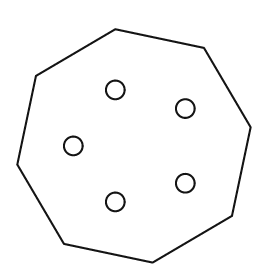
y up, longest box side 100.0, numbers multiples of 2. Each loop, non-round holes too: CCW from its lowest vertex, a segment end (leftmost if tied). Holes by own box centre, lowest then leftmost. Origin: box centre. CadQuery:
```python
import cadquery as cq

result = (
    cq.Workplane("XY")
    .moveTo(8.0, -50.0)
    .lineTo(42.0, -30.0)
    .lineTo(50.0, 8.0)
    .lineTo(30.0, 42.0)
    .lineTo(-8.0, 50.0)
    .lineTo(-42.0, 30.0)
    .lineTo(-50.0, -8.0)
    .lineTo(-30.0, -42.0)
    .close()
    .moveTo(-8.0, -24.0)
    .circle(4.0)
    .moveTo(22.0, -16.0)
    .circle(4.0)
    .moveTo(-26.0, 0.0)
    .circle(4.0)
    .moveTo(22.0, 16.0)
    .circle(4.0)
    .moveTo(-8.0, 24.0)
    .circle(4.0)
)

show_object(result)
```